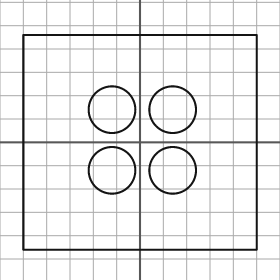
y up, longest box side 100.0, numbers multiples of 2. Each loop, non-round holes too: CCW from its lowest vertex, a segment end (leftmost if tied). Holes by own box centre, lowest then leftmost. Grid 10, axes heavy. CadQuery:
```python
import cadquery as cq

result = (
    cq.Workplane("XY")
    .moveTo(-50.0, -46.0)
    .lineTo(50.0, -46.0)
    .lineTo(50.0, 46.0)
    .lineTo(-50.0, 46.0)
    .close()
    .moveTo(-12.0, -12.0)
    .circle(10.0)
    .moveTo(14.0, -12.0)
    .circle(10.0)
    .moveTo(-12.0, 14.0)
    .circle(10.0)
    .moveTo(14.0, 14.0)
    .circle(10.0)
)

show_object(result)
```